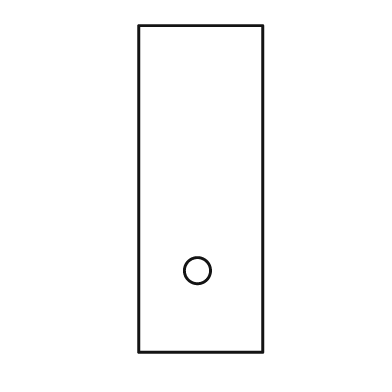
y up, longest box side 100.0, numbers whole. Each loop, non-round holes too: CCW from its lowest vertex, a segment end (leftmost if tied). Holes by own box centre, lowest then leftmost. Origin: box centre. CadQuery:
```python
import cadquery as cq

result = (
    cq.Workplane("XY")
    .moveTo(-19.0, -50.0)
    .lineTo(19.0, -50.0)
    .lineTo(19.0, 50.0)
    .lineTo(-19.0, 50.0)
    .close()
    .moveTo(-1.0, -25.0)
    .circle(4.0)
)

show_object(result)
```